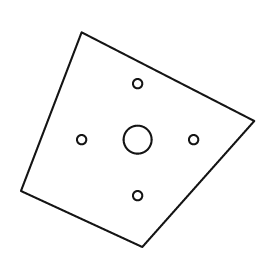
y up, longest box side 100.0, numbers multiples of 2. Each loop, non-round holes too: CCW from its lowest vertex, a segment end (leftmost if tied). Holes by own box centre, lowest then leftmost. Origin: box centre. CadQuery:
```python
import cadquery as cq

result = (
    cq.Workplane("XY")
    .moveTo(2.0, -46.0)
    .lineTo(50.0, 8.0)
    .lineTo(-24.0, 46.0)
    .lineTo(-50.0, -22.0)
    .close()
    .moveTo(0.0, -24.0)
    .circle(2.0)
    .moveTo(-24.0, 0.0)
    .circle(2.0)
    .moveTo(0.0, 0.0)
    .circle(6.0)
    .moveTo(24.0, 0.0)
    .circle(2.0)
    .moveTo(0.0, 24.0)
    .circle(2.0)
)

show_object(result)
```